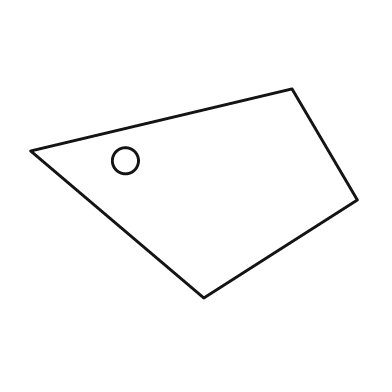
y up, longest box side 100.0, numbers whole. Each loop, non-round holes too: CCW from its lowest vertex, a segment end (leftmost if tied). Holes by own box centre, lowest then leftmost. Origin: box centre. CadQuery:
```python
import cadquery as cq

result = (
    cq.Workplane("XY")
    .moveTo(3.0, -32.0)
    .lineTo(50.0, -2.0)
    .lineTo(30.0, 32.0)
    .lineTo(-50.0, 13.0)
    .close()
    .moveTo(-21.0, 10.0)
    .circle(4.0)
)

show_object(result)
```